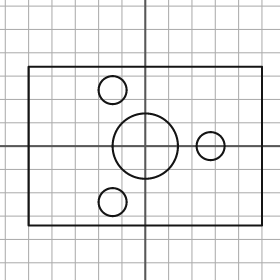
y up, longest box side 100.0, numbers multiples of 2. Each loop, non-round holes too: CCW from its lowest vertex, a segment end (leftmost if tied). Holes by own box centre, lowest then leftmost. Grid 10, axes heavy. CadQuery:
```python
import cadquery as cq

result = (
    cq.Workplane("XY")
    .moveTo(-50.0, -34.0)
    .lineTo(50.0, -34.0)
    .lineTo(50.0, 34.0)
    .lineTo(-50.0, 34.0)
    .close()
    .moveTo(-14.0, -24.0)
    .circle(6.0)
    .moveTo(0.0, 0.0)
    .circle(14.0)
    .moveTo(28.0, 0.0)
    .circle(6.0)
    .moveTo(-14.0, 24.0)
    .circle(6.0)
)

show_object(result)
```